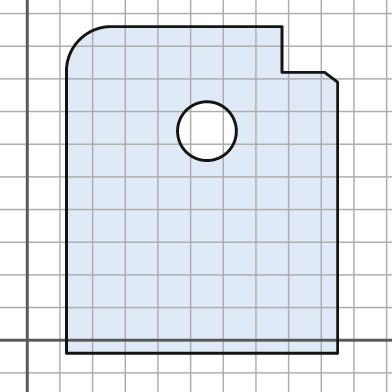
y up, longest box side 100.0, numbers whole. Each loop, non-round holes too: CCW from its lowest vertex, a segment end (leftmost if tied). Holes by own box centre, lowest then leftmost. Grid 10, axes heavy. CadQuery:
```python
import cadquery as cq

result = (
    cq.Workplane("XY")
    .moveTo(12.0, -4.0)
    .lineTo(95.0, -4.0)
    .lineTo(95.0, 79.0)
    .lineTo(91.0, 82.0)
    .lineTo(78.0, 82.0)
    .lineTo(78.0, 96.0)
    .lineTo(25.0, 96.0)
    .threePointArc((16.0, 92.0), (12.0, 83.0))
    .close()
    .moveTo(55.0, 64.0)
    .circle(9.0)
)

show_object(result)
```